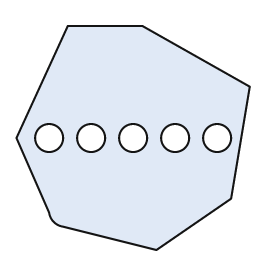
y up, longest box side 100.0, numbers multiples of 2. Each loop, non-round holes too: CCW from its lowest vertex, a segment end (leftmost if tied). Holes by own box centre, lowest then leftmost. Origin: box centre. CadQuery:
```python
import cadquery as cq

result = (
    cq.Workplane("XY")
    .moveTo(10.0, -48.0)
    .lineTo(42.0, -26.0)
    .lineTo(50.0, 22.0)
    .lineTo(4.0, 48.0)
    .lineTo(-28.0, 48.0)
    .lineTo(-50.0, 0.0)
    .lineTo(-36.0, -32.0)
    .threePointArc((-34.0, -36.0), (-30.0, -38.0))
    .close()
    .moveTo(-36.0, 0.0)
    .circle(6.0)
    .moveTo(-18.0, 0.0)
    .circle(6.0)
    .moveTo(0.0, 0.0)
    .circle(6.0)
    .moveTo(18.0, 0.0)
    .circle(6.0)
    .moveTo(36.0, 0.0)
    .circle(6.0)
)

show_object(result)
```